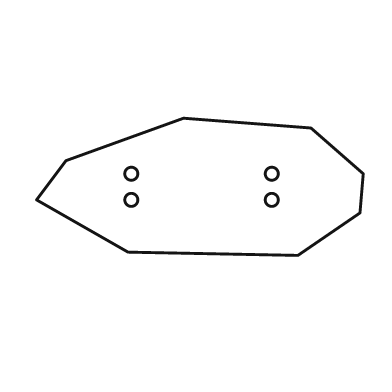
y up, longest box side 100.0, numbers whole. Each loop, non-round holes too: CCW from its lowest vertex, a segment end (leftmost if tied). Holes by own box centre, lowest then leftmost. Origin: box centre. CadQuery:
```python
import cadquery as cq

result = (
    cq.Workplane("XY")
    .moveTo(30.0, -21.0)
    .lineTo(49.0, -8.0)
    .lineTo(50.0, 4.0)
    .lineTo(34.0, 18.0)
    .lineTo(-5.0, 21.0)
    .lineTo(-41.0, 8.0)
    .lineTo(-50.0, -4.0)
    .lineTo(-22.0, -20.0)
    .close()
    .moveTo(-21.0, -4.0)
    .circle(2.0)
    .moveTo(22.0, -4.0)
    .circle(2.0)
    .moveTo(-21.0, 4.0)
    .circle(2.0)
    .moveTo(22.0, 4.0)
    .circle(2.0)
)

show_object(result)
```